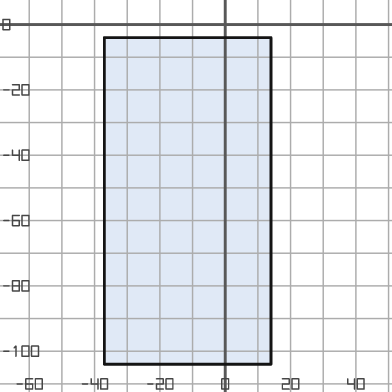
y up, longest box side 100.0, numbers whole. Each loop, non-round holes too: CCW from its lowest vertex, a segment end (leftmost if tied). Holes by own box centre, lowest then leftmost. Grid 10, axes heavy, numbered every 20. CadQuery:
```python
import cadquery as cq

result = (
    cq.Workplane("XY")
    .moveTo(-37.0, -104.0)
    .lineTo(14.0, -104.0)
    .lineTo(14.0, -4.0)
    .lineTo(-37.0, -4.0)
    .close()
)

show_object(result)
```